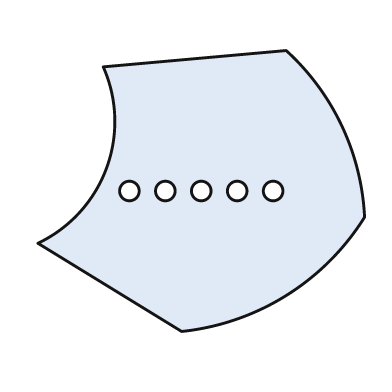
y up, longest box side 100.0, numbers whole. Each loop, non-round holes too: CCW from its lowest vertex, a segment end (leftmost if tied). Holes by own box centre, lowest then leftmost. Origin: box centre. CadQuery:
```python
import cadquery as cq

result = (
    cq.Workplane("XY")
    .moveTo(-6.0, -43.0)
    .threePointArc((26.0, -32.0), (50.0, -8.0))
    .threePointArc((43.0, 20.0), (26.0, 43.0))
    .lineTo(-30.0, 38.0)
    .threePointArc((-29.0, 7.0), (-50.0, -16.0))
    .close()
    .moveTo(-22.0, 0.0)
    .circle(3.0)
    .moveTo(-11.0, 0.0)
    .circle(3.0)
    .moveTo(0.0, 0.0)
    .circle(3.0)
    .moveTo(11.0, 0.0)
    .circle(3.0)
    .moveTo(22.0, 0.0)
    .circle(3.0)
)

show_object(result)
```